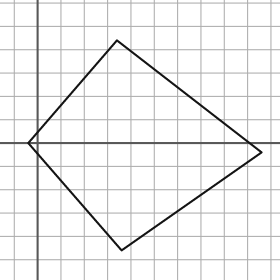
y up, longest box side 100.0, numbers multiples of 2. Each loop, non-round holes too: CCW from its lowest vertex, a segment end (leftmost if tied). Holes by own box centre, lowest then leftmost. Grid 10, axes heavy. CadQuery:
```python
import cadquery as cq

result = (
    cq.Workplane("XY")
    .moveTo(36.0, -46.0)
    .lineTo(96.0, -4.0)
    .lineTo(34.0, 44.0)
    .lineTo(-4.0, 0.0)
    .close()
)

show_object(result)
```